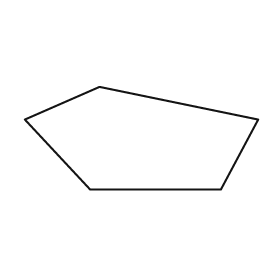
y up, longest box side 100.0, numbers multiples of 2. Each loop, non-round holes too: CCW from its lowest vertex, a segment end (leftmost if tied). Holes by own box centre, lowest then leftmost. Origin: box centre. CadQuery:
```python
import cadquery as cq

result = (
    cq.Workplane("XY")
    .moveTo(-22.0, -22.0)
    .lineTo(34.0, -22.0)
    .lineTo(50.0, 8.0)
    .lineTo(-18.0, 22.0)
    .lineTo(-50.0, 8.0)
    .close()
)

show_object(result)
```